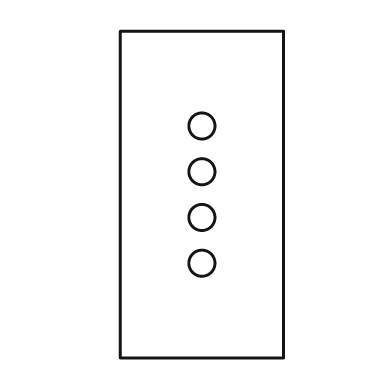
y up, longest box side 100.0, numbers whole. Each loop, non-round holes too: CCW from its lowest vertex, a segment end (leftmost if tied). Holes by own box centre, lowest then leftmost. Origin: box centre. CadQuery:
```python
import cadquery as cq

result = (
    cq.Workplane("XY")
    .moveTo(-25.0, -50.0)
    .lineTo(25.0, -50.0)
    .lineTo(25.0, 50.0)
    .lineTo(-25.0, 50.0)
    .close()
    .moveTo(0.0, -21.0)
    .circle(4.0)
    .moveTo(0.0, -7.0)
    .circle(4.0)
    .moveTo(0.0, 7.0)
    .circle(4.0)
    .moveTo(0.0, 21.0)
    .circle(4.0)
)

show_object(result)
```